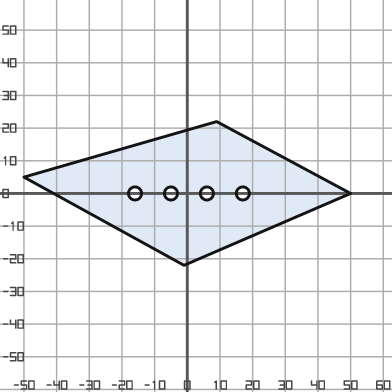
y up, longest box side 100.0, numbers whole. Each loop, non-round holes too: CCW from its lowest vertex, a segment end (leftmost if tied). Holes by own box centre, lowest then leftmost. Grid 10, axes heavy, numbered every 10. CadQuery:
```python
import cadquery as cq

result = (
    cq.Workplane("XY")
    .moveTo(-1.0, -22.0)
    .lineTo(50.0, 0.0)
    .lineTo(9.0, 22.0)
    .lineTo(-50.0, 5.0)
    .close()
    .moveTo(-16.0, 0.0)
    .circle(2.0)
    .moveTo(-5.0, 0.0)
    .circle(2.0)
    .moveTo(6.0, 0.0)
    .circle(2.0)
    .moveTo(17.0, 0.0)
    .circle(2.0)
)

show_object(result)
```